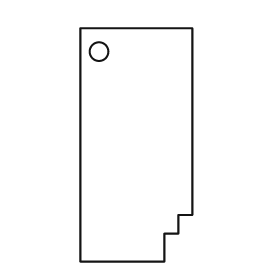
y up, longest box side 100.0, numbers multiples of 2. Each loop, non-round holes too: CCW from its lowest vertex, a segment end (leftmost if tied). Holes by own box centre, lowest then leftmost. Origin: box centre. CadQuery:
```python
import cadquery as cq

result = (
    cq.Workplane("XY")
    .moveTo(-24.0, -50.0)
    .lineTo(12.0, -50.0)
    .lineTo(12.0, -38.0)
    .lineTo(18.0, -38.0)
    .lineTo(18.0, -30.0)
    .lineTo(24.0, -30.0)
    .lineTo(24.0, 50.0)
    .lineTo(-24.0, 50.0)
    .close()
    .moveTo(-16.0, 40.0)
    .circle(4.0)
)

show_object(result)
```